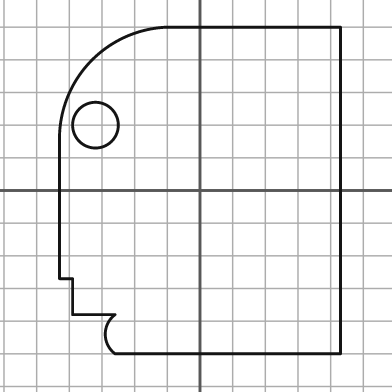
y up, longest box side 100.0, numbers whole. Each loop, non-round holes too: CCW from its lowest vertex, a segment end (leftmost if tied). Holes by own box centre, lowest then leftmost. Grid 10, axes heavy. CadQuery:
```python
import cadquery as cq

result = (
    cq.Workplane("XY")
    .moveTo(-26.0, -50.0)
    .lineTo(43.0, -50.0)
    .lineTo(43.0, 50.0)
    .lineTo(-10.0, 50.0)
    .threePointArc((-33.0, 40.0), (-43.0, 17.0))
    .lineTo(-43.0, -27.0)
    .lineTo(-39.0, -27.0)
    .lineTo(-39.0, -38.0)
    .lineTo(-26.0, -38.0)
    .threePointArc((-29.0, -44.0), (-26.0, -50.0))
    .close()
    .moveTo(-32.0, 20.0)
    .circle(7.0)
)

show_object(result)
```